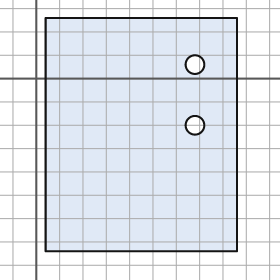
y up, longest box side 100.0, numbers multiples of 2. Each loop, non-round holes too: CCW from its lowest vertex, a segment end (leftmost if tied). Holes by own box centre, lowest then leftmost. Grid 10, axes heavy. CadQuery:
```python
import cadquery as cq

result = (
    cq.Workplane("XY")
    .moveTo(4.0, -74.0)
    .lineTo(86.0, -74.0)
    .lineTo(86.0, 26.0)
    .lineTo(4.0, 26.0)
    .close()
    .moveTo(68.0, -20.0)
    .circle(4.0)
    .moveTo(68.0, 6.0)
    .circle(4.0)
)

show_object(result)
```